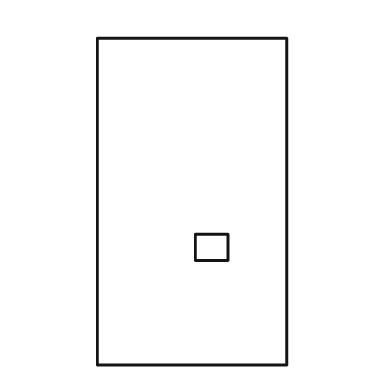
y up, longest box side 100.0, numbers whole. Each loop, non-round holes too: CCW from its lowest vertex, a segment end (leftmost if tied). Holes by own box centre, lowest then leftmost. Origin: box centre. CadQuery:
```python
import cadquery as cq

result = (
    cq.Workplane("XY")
    .moveTo(-29.0, -50.0)
    .lineTo(29.0, -50.0)
    .lineTo(29.0, 50.0)
    .lineTo(-29.0, 50.0)
    .close()
    .moveTo(1.0, -18.0)
    .lineTo(11.0, -18.0)
    .lineTo(11.0, -10.0)
    .lineTo(1.0, -10.0)
    .close()
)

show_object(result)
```